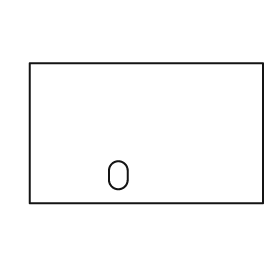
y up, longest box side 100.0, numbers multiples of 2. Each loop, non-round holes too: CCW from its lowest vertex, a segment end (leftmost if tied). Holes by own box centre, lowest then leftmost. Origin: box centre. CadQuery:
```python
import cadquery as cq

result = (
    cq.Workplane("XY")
    .moveTo(-50.0, -30.0)
    .lineTo(50.0, -30.0)
    .lineTo(50.0, 30.0)
    .lineTo(-50.0, 30.0)
    .close()
    .moveTo(-16.0, -20.0)
    .threePointArc((-12.0, -24.0), (-8.0, -20.0))
    .lineTo(-8.0, -16.0)
    .threePointArc((-12.0, -12.0), (-16.0, -16.0))
    .close()
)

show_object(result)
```